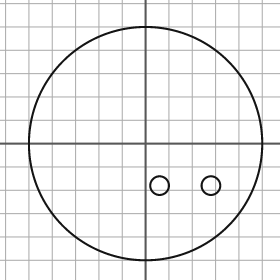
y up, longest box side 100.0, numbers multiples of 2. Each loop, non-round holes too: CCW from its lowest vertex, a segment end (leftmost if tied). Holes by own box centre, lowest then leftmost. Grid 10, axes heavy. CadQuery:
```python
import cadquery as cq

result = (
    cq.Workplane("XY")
    .moveTo(0.0, 0.0)
    .circle(50.0)
    .moveTo(6.0, -18.0)
    .circle(4.0)
    .moveTo(28.0, -18.0)
    .circle(4.0)
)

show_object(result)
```